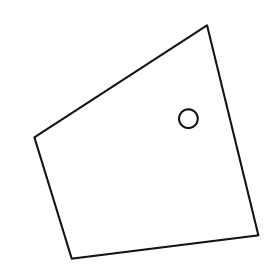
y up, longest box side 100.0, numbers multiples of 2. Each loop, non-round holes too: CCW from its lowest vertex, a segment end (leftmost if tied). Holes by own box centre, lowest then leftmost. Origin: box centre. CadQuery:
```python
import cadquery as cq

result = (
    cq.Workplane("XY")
    .moveTo(-32.0, -50.0)
    .lineTo(48.0, -40.0)
    .lineTo(26.0, 50.0)
    .lineTo(-48.0, 2.0)
    .close()
    .moveTo(18.0, 10.0)
    .circle(4.0)
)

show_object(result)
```